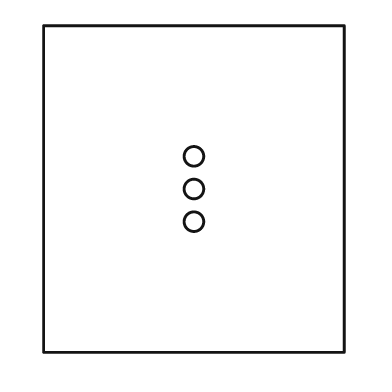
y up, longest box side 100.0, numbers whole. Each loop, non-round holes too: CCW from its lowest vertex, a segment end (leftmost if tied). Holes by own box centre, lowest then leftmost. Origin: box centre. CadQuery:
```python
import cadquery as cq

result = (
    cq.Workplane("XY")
    .moveTo(-46.0, -50.0)
    .lineTo(46.0, -50.0)
    .lineTo(46.0, 50.0)
    .lineTo(-46.0, 50.0)
    .close()
    .moveTo(0.0, -10.0)
    .circle(3.0)
    .moveTo(0.0, 0.0)
    .circle(3.0)
    .moveTo(0.0, 10.0)
    .circle(3.0)
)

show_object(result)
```